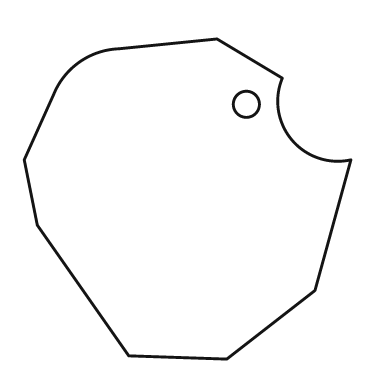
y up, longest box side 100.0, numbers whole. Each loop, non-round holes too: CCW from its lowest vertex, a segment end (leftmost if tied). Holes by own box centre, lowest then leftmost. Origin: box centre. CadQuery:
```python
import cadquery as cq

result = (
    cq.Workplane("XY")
    .moveTo(12.0, -49.0)
    .lineTo(39.0, -28.0)
    .lineTo(50.0, 12.0)
    .threePointArc((32.0, 18.0), (29.0, 37.0))
    .lineTo(9.0, 49.0)
    .lineTo(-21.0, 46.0)
    .threePointArc((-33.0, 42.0), (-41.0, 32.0))
    .lineTo(-50.0, 12.0)
    .lineTo(-46.0, -8.0)
    .lineTo(-18.0, -48.0)
    .close()
    .moveTo(18.0, 29.0)
    .circle(4.0)
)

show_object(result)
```